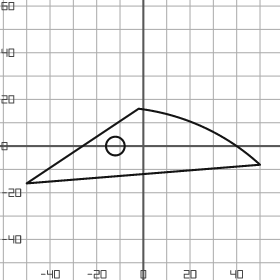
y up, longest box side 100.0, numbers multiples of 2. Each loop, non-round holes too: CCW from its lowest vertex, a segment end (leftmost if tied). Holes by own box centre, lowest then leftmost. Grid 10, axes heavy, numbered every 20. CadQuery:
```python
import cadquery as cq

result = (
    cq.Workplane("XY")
    .moveTo(-50.0, -16.0)
    .lineTo(50.0, -8.0)
    .threePointArc((26.0, 8.0), (-2.0, 16.0))
    .close()
    .moveTo(-12.0, 0.0)
    .circle(4.0)
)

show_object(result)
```